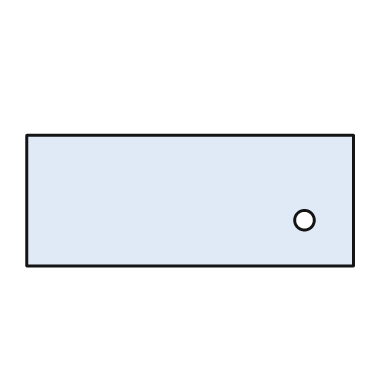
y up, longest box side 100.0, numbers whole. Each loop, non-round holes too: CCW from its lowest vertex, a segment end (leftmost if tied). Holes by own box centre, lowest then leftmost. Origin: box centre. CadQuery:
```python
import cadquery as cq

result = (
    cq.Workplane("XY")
    .moveTo(-50.0, -20.0)
    .lineTo(50.0, -20.0)
    .lineTo(50.0, 20.0)
    .lineTo(-50.0, 20.0)
    .close()
    .moveTo(35.0, -6.0)
    .circle(3.0)
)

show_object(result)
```